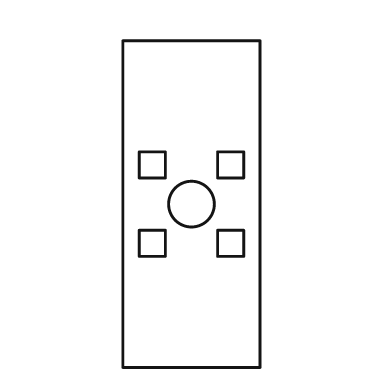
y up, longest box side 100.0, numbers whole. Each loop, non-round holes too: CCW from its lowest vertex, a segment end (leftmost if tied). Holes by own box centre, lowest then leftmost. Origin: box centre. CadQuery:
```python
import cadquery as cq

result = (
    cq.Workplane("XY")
    .moveTo(-21.0, -50.0)
    .lineTo(21.0, -50.0)
    .lineTo(21.0, 50.0)
    .lineTo(-21.0, 50.0)
    .close()
    .moveTo(-16.0, -16.0)
    .lineTo(-8.0, -16.0)
    .lineTo(-8.0, -8.0)
    .lineTo(-16.0, -8.0)
    .close()
    .moveTo(8.0, -16.0)
    .lineTo(16.0, -16.0)
    .lineTo(16.0, -8.0)
    .lineTo(8.0, -8.0)
    .close()
    .moveTo(0.0, 0.0)
    .circle(7.0)
    .moveTo(-16.0, 8.0)
    .lineTo(-8.0, 8.0)
    .lineTo(-8.0, 16.0)
    .lineTo(-16.0, 16.0)
    .close()
    .moveTo(8.0, 8.0)
    .lineTo(16.0, 8.0)
    .lineTo(16.0, 16.0)
    .lineTo(8.0, 16.0)
    .close()
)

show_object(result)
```